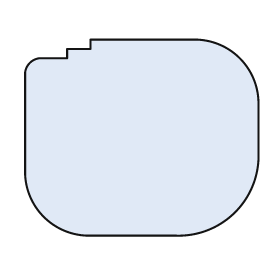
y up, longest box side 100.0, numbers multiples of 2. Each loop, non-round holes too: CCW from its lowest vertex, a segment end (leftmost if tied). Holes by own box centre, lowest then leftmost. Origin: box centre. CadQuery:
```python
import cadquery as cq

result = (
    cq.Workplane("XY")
    .moveTo(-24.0, -42.0)
    .lineTo(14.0, -42.0)
    .threePointArc((40.0, -32.0), (50.0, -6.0))
    .lineTo(50.0, 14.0)
    .threePointArc((42.0, 34.0), (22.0, 42.0))
    .lineTo(-22.0, 42.0)
    .lineTo(-22.0, 38.0)
    .lineTo(-32.0, 38.0)
    .lineTo(-32.0, 34.0)
    .lineTo(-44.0, 34.0)
    .threePointArc((-48.0, 32.0), (-50.0, 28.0))
    .lineTo(-50.0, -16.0)
    .threePointArc((-42.0, -34.0), (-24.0, -42.0))
    .close()
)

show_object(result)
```